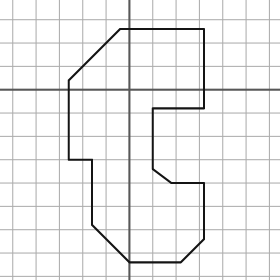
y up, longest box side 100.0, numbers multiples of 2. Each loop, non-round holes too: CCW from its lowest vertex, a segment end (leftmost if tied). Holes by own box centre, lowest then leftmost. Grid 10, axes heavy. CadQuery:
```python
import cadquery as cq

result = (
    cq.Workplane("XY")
    .moveTo(0.0, -74.0)
    .lineTo(22.0, -74.0)
    .lineTo(32.0, -64.0)
    .lineTo(32.0, -40.0)
    .lineTo(18.0, -40.0)
    .lineTo(10.0, -34.0)
    .lineTo(10.0, -8.0)
    .lineTo(32.0, -8.0)
    .lineTo(32.0, 26.0)
    .lineTo(-4.0, 26.0)
    .lineTo(-26.0, 4.0)
    .lineTo(-26.0, -30.0)
    .lineTo(-16.0, -30.0)
    .lineTo(-16.0, -58.0)
    .close()
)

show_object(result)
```